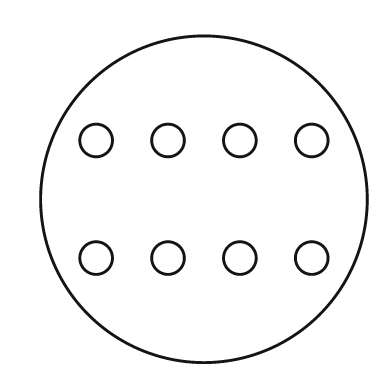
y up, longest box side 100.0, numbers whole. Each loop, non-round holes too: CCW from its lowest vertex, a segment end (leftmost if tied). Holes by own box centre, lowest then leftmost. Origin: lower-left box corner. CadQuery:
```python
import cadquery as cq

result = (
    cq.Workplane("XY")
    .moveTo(50.0, 50.0)
    .circle(50.0)
    .moveTo(17.0, 32.0)
    .circle(5.0)
    .moveTo(39.0, 32.0)
    .circle(5.0)
    .moveTo(61.0, 32.0)
    .circle(5.0)
    .moveTo(83.0, 32.0)
    .circle(5.0)
    .moveTo(17.0, 68.0)
    .circle(5.0)
    .moveTo(39.0, 68.0)
    .circle(5.0)
    .moveTo(61.0, 68.0)
    .circle(5.0)
    .moveTo(83.0, 68.0)
    .circle(5.0)
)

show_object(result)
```